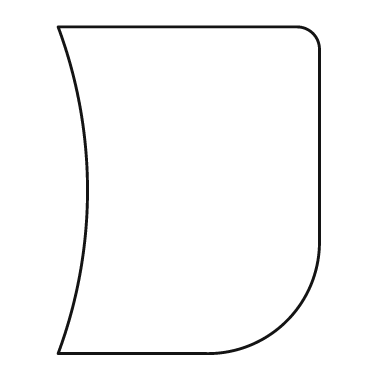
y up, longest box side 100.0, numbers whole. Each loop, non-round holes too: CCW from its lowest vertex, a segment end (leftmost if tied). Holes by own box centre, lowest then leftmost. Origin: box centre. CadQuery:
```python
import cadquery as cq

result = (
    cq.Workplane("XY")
    .moveTo(-40.0, -50.0)
    .lineTo(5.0, -50.0)
    .threePointArc((30.0, -40.0), (40.0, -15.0))
    .lineTo(40.0, 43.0)
    .threePointArc((38.0, 48.0), (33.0, 50.0))
    .lineTo(-40.0, 50.0)
    .threePointArc((-31.0, 0.0), (-40.0, -50.0))
    .close()
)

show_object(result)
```